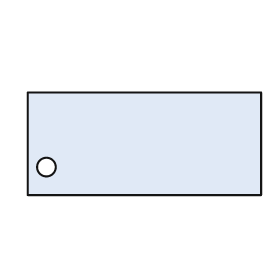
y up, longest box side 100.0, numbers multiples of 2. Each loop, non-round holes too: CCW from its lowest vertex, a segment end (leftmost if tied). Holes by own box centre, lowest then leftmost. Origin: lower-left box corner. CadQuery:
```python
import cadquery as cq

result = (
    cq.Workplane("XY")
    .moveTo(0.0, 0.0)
    .lineTo(100.0, 0.0)
    .lineTo(100.0, 44.0)
    .lineTo(0.0, 44.0)
    .close()
    .moveTo(8.0, 12.0)
    .circle(4.0)
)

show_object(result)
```